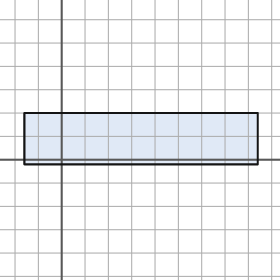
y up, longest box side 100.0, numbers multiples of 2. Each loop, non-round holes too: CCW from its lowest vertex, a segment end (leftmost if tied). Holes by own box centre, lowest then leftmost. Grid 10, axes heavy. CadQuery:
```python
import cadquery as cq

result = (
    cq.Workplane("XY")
    .moveTo(-16.0, -2.0)
    .lineTo(84.0, -2.0)
    .lineTo(84.0, 20.0)
    .lineTo(-16.0, 20.0)
    .close()
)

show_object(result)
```